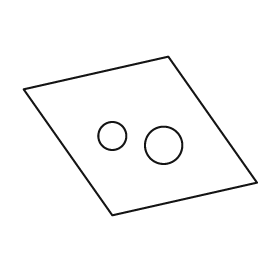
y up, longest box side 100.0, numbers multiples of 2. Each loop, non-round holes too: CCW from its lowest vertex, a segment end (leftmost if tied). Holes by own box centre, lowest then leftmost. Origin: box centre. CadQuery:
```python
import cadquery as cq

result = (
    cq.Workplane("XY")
    .moveTo(-12.0, -34.0)
    .lineTo(50.0, -20.0)
    .lineTo(12.0, 34.0)
    .lineTo(-50.0, 20.0)
    .close()
    .moveTo(10.0, -4.0)
    .circle(8.0)
    .moveTo(-12.0, 0.0)
    .circle(6.0)
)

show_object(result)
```